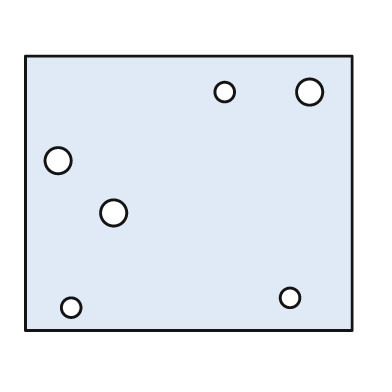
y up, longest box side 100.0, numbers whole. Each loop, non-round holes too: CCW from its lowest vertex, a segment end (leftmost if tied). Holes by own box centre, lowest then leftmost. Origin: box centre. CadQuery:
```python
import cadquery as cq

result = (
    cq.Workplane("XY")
    .moveTo(-50.0, -42.0)
    .lineTo(50.0, -42.0)
    .lineTo(50.0, 42.0)
    .lineTo(-50.0, 42.0)
    .close()
    .moveTo(-36.0, -35.0)
    .circle(3.0)
    .moveTo(31.0, -32.0)
    .circle(3.0)
    .moveTo(-23.0, -6.0)
    .circle(4.0)
    .moveTo(-40.0, 10.0)
    .circle(4.0)
    .moveTo(11.0, 31.0)
    .circle(3.0)
    .moveTo(37.0, 31.0)
    .circle(4.0)
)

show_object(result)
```